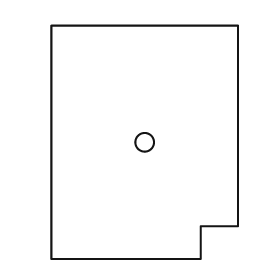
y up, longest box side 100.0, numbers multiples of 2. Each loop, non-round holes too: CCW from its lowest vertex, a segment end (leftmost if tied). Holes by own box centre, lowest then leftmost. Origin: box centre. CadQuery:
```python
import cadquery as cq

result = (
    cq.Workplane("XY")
    .moveTo(-40.0, -50.0)
    .lineTo(24.0, -50.0)
    .lineTo(24.0, -36.0)
    .lineTo(40.0, -36.0)
    .lineTo(40.0, 50.0)
    .lineTo(-40.0, 50.0)
    .close()
    .moveTo(0.0, 0.0)
    .circle(4.0)
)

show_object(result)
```